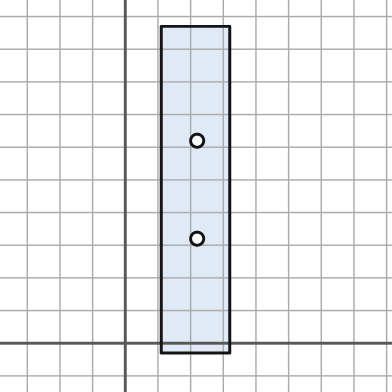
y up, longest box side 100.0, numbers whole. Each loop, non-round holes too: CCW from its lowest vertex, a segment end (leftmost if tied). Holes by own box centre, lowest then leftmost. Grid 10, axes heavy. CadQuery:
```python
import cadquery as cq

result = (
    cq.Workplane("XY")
    .moveTo(11.0, -3.0)
    .lineTo(32.0, -3.0)
    .lineTo(32.0, 97.0)
    .lineTo(11.0, 97.0)
    .close()
    .moveTo(22.0, 32.0)
    .circle(2.0)
    .moveTo(22.0, 62.0)
    .circle(2.0)
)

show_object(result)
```